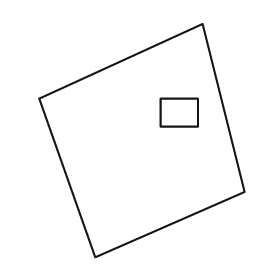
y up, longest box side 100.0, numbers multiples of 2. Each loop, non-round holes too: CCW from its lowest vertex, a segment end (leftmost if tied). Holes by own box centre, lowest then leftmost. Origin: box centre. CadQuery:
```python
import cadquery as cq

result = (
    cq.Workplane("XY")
    .moveTo(-20.0, -50.0)
    .lineTo(44.0, -22.0)
    .lineTo(26.0, 50.0)
    .lineTo(-44.0, 18.0)
    .close()
    .moveTo(8.0, 6.0)
    .lineTo(24.0, 6.0)
    .lineTo(24.0, 18.0)
    .lineTo(8.0, 18.0)
    .close()
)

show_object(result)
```